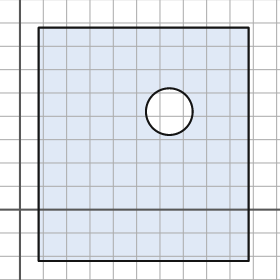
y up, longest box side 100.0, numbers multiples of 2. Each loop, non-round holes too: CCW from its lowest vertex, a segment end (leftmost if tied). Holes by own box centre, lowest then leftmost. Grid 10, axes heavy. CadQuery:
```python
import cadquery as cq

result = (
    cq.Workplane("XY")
    .moveTo(8.0, -22.0)
    .lineTo(98.0, -22.0)
    .lineTo(98.0, 78.0)
    .lineTo(8.0, 78.0)
    .close()
    .moveTo(64.0, 42.0)
    .circle(10.0)
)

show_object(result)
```